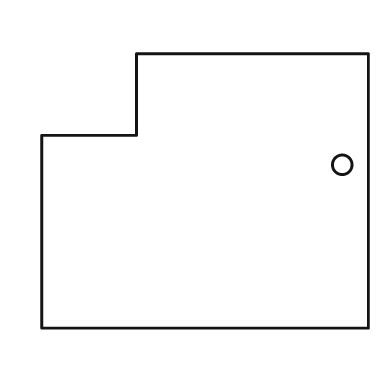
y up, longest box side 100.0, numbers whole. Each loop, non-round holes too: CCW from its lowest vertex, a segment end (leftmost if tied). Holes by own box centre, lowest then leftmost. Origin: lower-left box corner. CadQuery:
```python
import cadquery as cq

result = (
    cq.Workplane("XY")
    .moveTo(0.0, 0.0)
    .lineTo(100.0, 0.0)
    .lineTo(100.0, 84.0)
    .lineTo(29.0, 84.0)
    .lineTo(29.0, 59.0)
    .lineTo(0.0, 59.0)
    .close()
    .moveTo(92.0, 50.0)
    .circle(3.0)
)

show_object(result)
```